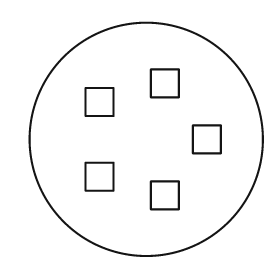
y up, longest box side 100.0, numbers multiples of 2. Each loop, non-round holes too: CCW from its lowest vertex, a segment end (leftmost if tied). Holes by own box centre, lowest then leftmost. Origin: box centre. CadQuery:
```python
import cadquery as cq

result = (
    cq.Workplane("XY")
    .moveTo(0.0, 0.0)
    .circle(50.0)
    .moveTo(2.0, -30.0)
    .lineTo(14.0, -30.0)
    .lineTo(14.0, -18.0)
    .lineTo(2.0, -18.0)
    .close()
    .moveTo(-26.0, -22.0)
    .lineTo(-14.0, -22.0)
    .lineTo(-14.0, -10.0)
    .lineTo(-26.0, -10.0)
    .close()
    .moveTo(20.0, -6.0)
    .lineTo(32.0, -6.0)
    .lineTo(32.0, 6.0)
    .lineTo(20.0, 6.0)
    .close()
    .moveTo(-26.0, 10.0)
    .lineTo(-14.0, 10.0)
    .lineTo(-14.0, 22.0)
    .lineTo(-26.0, 22.0)
    .close()
    .moveTo(2.0, 18.0)
    .lineTo(14.0, 18.0)
    .lineTo(14.0, 30.0)
    .lineTo(2.0, 30.0)
    .close()
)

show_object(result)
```